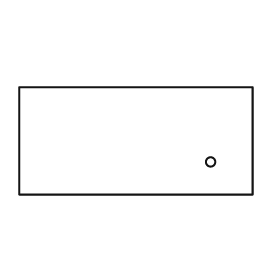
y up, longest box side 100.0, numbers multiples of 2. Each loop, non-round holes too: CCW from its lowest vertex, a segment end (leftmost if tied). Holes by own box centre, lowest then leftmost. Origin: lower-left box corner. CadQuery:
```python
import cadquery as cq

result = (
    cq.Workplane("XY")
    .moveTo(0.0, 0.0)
    .lineTo(100.0, 0.0)
    .lineTo(100.0, 46.0)
    .lineTo(0.0, 46.0)
    .close()
    .moveTo(82.0, 14.0)
    .circle(2.0)
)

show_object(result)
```